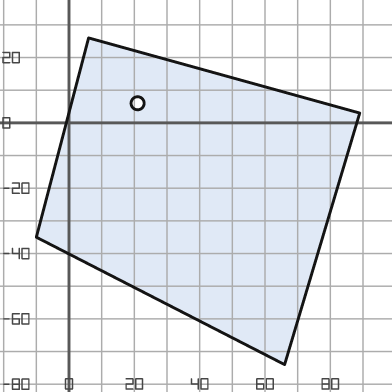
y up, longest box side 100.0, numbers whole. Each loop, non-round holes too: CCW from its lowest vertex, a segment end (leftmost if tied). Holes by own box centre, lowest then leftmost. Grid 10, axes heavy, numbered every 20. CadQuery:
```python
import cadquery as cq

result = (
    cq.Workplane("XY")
    .moveTo(66.0, -74.0)
    .lineTo(89.0, 3.0)
    .lineTo(6.0, 26.0)
    .lineTo(-10.0, -35.0)
    .close()
    .moveTo(21.0, 6.0)
    .circle(2.0)
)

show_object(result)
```